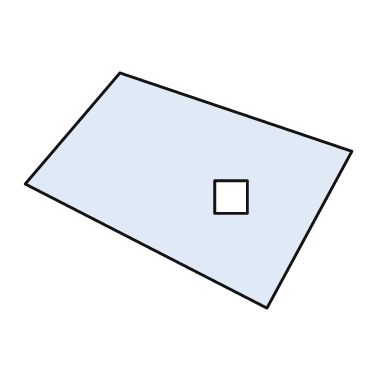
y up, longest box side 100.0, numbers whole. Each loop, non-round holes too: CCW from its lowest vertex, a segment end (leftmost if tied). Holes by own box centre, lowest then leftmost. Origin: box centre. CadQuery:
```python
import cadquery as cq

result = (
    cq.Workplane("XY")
    .moveTo(24.0, -36.0)
    .lineTo(50.0, 12.0)
    .lineTo(-21.0, 36.0)
    .lineTo(-50.0, 2.0)
    .close()
    .moveTo(8.0, -7.0)
    .lineTo(18.0, -7.0)
    .lineTo(18.0, 3.0)
    .lineTo(8.0, 3.0)
    .close()
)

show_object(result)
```